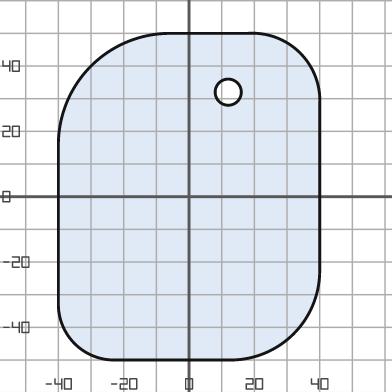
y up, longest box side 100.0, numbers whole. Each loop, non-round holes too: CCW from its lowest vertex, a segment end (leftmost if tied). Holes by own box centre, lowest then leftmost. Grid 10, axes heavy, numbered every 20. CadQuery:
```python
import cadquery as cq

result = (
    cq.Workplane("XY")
    .moveTo(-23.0, -50.0)
    .lineTo(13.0, -50.0)
    .threePointArc((32.0, -42.0), (40.0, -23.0))
    .lineTo(40.0, 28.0)
    .threePointArc((34.0, 44.0), (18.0, 50.0))
    .lineTo(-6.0, 50.0)
    .threePointArc((-30.0, 40.0), (-40.0, 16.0))
    .lineTo(-40.0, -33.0)
    .threePointArc((-35.0, -45.0), (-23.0, -50.0))
    .close()
    .moveTo(12.0, 32.0)
    .circle(4.0)
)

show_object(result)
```